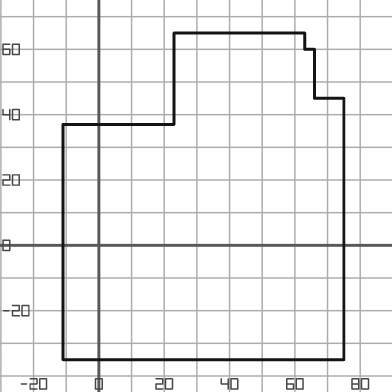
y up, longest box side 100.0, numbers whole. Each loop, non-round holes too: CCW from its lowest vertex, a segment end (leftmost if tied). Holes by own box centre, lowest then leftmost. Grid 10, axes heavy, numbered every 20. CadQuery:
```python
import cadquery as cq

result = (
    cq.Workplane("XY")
    .moveTo(-11.0, -35.0)
    .lineTo(75.0, -35.0)
    .lineTo(75.0, 45.0)
    .lineTo(66.0, 45.0)
    .lineTo(66.0, 60.0)
    .lineTo(63.0, 60.0)
    .lineTo(63.0, 65.0)
    .lineTo(23.0, 65.0)
    .lineTo(23.0, 37.0)
    .lineTo(-11.0, 37.0)
    .close()
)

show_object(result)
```